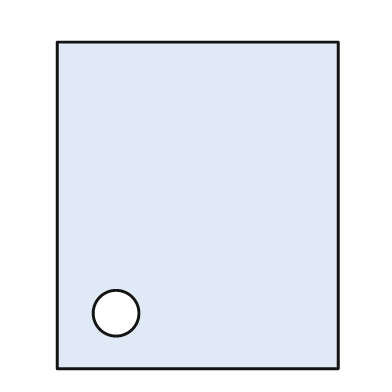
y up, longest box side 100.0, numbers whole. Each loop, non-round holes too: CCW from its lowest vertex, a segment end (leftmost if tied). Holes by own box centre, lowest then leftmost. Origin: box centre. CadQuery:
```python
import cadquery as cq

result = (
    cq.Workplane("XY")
    .moveTo(-43.0, -50.0)
    .lineTo(43.0, -50.0)
    .lineTo(43.0, 50.0)
    .lineTo(-43.0, 50.0)
    .close()
    .moveTo(-25.0, -33.0)
    .circle(7.0)
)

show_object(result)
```